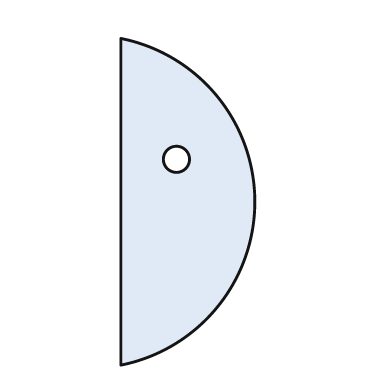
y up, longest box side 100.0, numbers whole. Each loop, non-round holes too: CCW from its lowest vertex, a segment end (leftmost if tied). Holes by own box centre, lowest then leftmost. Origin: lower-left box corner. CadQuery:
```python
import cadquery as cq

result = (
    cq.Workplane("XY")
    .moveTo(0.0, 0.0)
    .threePointArc((41.0, 50.0), (0.0, 100.0))
    .close()
    .moveTo(17.0, 63.0)
    .circle(4.0)
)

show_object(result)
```